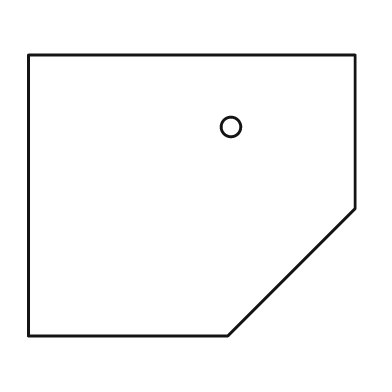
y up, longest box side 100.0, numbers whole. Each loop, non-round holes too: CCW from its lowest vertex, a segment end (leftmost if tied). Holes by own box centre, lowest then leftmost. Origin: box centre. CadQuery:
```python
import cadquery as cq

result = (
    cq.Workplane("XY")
    .moveTo(-50.0, -43.0)
    .lineTo(11.0, -43.0)
    .lineTo(50.0, -4.0)
    .lineTo(50.0, 43.0)
    .lineTo(-50.0, 43.0)
    .close()
    .moveTo(12.0, 21.0)
    .circle(3.0)
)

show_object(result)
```